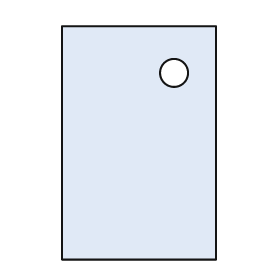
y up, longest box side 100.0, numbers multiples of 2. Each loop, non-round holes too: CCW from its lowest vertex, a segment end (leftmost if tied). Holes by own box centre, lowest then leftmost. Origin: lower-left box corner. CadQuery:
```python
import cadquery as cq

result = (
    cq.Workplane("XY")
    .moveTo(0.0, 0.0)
    .lineTo(66.0, 0.0)
    .lineTo(66.0, 100.0)
    .lineTo(0.0, 100.0)
    .close()
    .moveTo(48.0, 80.0)
    .circle(6.0)
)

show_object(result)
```